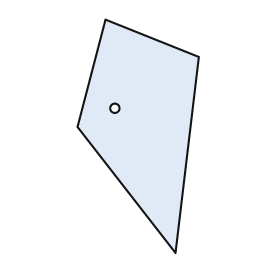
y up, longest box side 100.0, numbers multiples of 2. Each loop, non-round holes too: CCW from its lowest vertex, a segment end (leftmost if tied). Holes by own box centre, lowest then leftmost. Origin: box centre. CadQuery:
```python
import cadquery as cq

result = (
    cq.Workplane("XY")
    .moveTo(16.0, -50.0)
    .lineTo(26.0, 34.0)
    .lineTo(-14.0, 50.0)
    .lineTo(-26.0, 4.0)
    .close()
    .moveTo(-10.0, 12.0)
    .circle(2.0)
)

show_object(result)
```